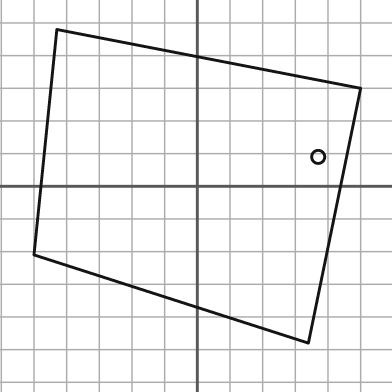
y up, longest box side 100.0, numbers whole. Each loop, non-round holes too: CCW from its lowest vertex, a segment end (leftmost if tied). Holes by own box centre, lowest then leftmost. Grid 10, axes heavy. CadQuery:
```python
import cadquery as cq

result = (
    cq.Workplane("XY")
    .moveTo(34.0, -48.0)
    .lineTo(50.0, 30.0)
    .lineTo(-43.0, 48.0)
    .lineTo(-50.0, -21.0)
    .close()
    .moveTo(37.0, 9.0)
    .circle(2.0)
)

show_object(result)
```